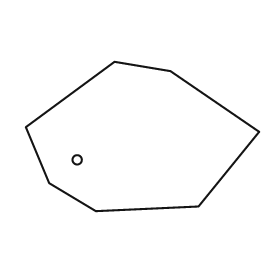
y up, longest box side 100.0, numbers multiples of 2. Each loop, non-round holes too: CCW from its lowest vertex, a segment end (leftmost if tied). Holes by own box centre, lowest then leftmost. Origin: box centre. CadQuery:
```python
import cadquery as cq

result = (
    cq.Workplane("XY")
    .moveTo(-20.0, -32.0)
    .lineTo(24.0, -30.0)
    .lineTo(50.0, 2.0)
    .lineTo(12.0, 28.0)
    .lineTo(-12.0, 32.0)
    .lineTo(-50.0, 4.0)
    .lineTo(-40.0, -20.0)
    .close()
    .moveTo(-28.0, -10.0)
    .circle(2.0)
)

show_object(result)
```